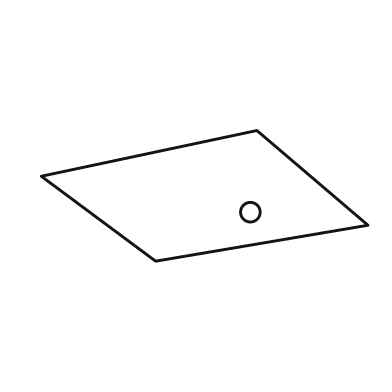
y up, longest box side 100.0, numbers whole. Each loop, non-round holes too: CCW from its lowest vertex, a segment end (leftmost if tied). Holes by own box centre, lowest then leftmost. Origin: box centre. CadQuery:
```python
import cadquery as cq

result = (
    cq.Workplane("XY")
    .moveTo(-15.0, -20.0)
    .lineTo(50.0, -9.0)
    .lineTo(16.0, 20.0)
    .lineTo(-50.0, 6.0)
    .close()
    .moveTo(14.0, -5.0)
    .circle(3.0)
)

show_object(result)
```